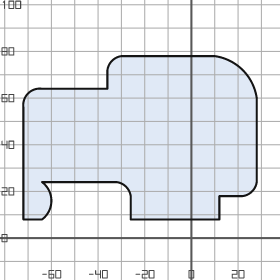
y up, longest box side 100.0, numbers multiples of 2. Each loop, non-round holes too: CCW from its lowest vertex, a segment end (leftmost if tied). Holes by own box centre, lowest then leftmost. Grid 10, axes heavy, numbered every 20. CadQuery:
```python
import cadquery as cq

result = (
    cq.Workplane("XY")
    .moveTo(-72.0, 8.0)
    .lineTo(-64.0, 8.0)
    .threePointArc((-60.0, 16.0), (-64.0, 24.0))
    .lineTo(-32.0, 24.0)
    .threePointArc((-28.0, 22.0), (-26.0, 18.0))
    .lineTo(-26.0, 8.0)
    .lineTo(12.0, 8.0)
    .lineTo(12.0, 18.0)
    .lineTo(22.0, 18.0)
    .threePointArc((26.0, 20.0), (28.0, 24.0))
    .lineTo(28.0, 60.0)
    .threePointArc((22.0, 72.0), (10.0, 78.0))
    .lineTo(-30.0, 78.0)
    .threePointArc((-34.0, 76.0), (-36.0, 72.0))
    .lineTo(-36.0, 64.0)
    .lineTo(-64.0, 64.0)
    .threePointArc((-70.0, 62.0), (-72.0, 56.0))
    .close()
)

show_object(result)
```